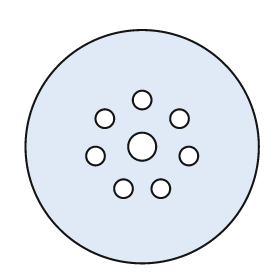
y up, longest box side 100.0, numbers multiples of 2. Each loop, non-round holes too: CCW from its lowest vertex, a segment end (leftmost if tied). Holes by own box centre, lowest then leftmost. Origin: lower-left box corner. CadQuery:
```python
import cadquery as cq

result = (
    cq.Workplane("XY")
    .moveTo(50.0, 50.0)
    .circle(50.0)
    .moveTo(42.0, 32.0)
    .circle(4.0)
    .moveTo(58.0, 32.0)
    .circle(4.0)
    .moveTo(30.0, 46.0)
    .circle(4.0)
    .moveTo(70.0, 46.0)
    .circle(4.0)
    .moveTo(50.0, 50.0)
    .circle(6.0)
    .moveTo(34.0, 62.0)
    .circle(4.0)
    .moveTo(66.0, 62.0)
    .circle(4.0)
    .moveTo(50.0, 70.0)
    .circle(4.0)
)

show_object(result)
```